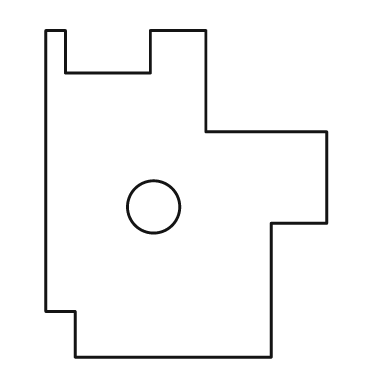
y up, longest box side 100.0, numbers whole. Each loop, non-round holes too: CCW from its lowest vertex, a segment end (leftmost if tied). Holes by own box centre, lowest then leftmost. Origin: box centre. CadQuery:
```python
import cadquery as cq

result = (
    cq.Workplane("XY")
    .moveTo(-34.0, -50.0)
    .lineTo(26.0, -50.0)
    .lineTo(26.0, -9.0)
    .lineTo(43.0, -9.0)
    .lineTo(43.0, 19.0)
    .lineTo(6.0, 19.0)
    .lineTo(6.0, 50.0)
    .lineTo(-11.0, 50.0)
    .lineTo(-11.0, 37.0)
    .lineTo(-37.0, 37.0)
    .lineTo(-37.0, 50.0)
    .lineTo(-43.0, 50.0)
    .lineTo(-43.0, -36.0)
    .lineTo(-34.0, -36.0)
    .close()
    .moveTo(-10.0, -4.0)
    .circle(8.0)
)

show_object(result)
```